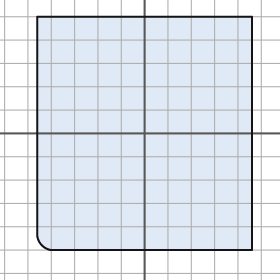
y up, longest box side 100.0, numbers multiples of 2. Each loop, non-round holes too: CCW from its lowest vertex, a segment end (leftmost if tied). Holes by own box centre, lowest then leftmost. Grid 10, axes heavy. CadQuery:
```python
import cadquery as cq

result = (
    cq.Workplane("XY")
    .moveTo(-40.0, -50.0)
    .lineTo(46.0, -50.0)
    .lineTo(46.0, 50.0)
    .lineTo(-46.0, 50.0)
    .lineTo(-46.0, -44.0)
    .threePointArc((-44.0, -48.0), (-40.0, -50.0))
    .close()
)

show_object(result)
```